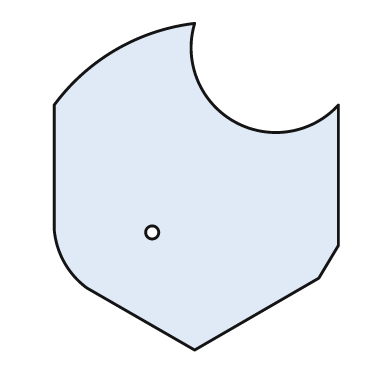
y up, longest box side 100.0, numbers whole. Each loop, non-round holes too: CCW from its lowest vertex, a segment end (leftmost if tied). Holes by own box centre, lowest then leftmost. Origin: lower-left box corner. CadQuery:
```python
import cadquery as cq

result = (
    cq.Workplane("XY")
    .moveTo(43.0, 0.0)
    .lineTo(81.0, 22.0)
    .lineTo(87.0, 32.0)
    .lineTo(87.0, 75.0)
    .threePointArc((55.0, 70.0), (43.0, 100.0))
    .threePointArc((19.0, 92.0), (0.0, 75.0))
    .lineTo(0.0, 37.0)
    .threePointArc((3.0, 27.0), (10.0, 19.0))
    .close()
    .moveTo(30.0, 36.0)
    .circle(2.0)
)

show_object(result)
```